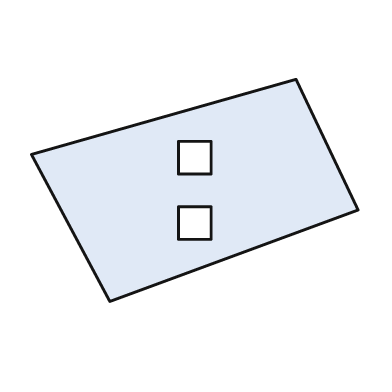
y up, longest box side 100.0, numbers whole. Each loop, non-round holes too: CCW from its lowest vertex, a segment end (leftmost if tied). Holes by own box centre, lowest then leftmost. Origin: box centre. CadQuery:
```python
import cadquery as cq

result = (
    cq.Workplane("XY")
    .moveTo(-26.0, -34.0)
    .lineTo(50.0, -6.0)
    .lineTo(31.0, 34.0)
    .lineTo(-50.0, 11.0)
    .close()
    .moveTo(-5.0, -15.0)
    .lineTo(5.0, -15.0)
    .lineTo(5.0, -5.0)
    .lineTo(-5.0, -5.0)
    .close()
    .moveTo(-5.0, 5.0)
    .lineTo(5.0, 5.0)
    .lineTo(5.0, 15.0)
    .lineTo(-5.0, 15.0)
    .close()
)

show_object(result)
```